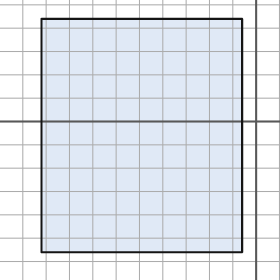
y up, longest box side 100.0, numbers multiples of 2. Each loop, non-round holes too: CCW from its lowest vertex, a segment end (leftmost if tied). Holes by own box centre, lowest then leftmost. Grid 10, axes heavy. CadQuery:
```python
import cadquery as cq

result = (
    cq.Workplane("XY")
    .moveTo(-92.0, -56.0)
    .lineTo(-6.0, -56.0)
    .lineTo(-6.0, 44.0)
    .lineTo(-92.0, 44.0)
    .close()
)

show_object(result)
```